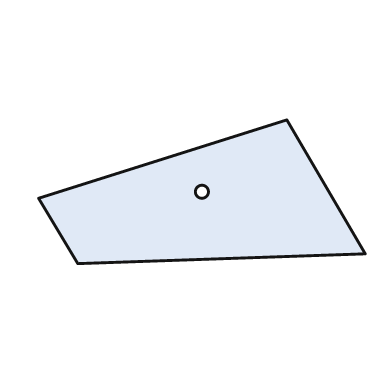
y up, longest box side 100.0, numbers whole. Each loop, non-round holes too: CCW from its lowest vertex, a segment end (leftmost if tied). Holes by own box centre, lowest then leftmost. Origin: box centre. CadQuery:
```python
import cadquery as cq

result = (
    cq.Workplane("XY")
    .moveTo(-38.0, -22.0)
    .lineTo(50.0, -19.0)
    .lineTo(26.0, 22.0)
    .lineTo(-50.0, -2.0)
    .close()
    .moveTo(0.0, 0.0)
    .circle(2.0)
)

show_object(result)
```